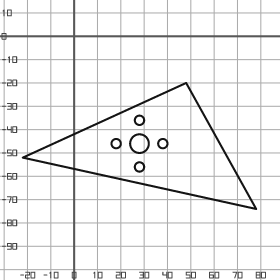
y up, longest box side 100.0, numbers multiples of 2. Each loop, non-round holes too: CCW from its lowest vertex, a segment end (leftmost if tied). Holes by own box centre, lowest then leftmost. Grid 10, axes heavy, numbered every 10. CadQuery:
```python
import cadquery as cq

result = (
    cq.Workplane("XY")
    .moveTo(78.0, -74.0)
    .lineTo(48.0, -20.0)
    .lineTo(-22.0, -52.0)
    .close()
    .moveTo(28.0, -56.0)
    .circle(2.0)
    .moveTo(18.0, -46.0)
    .circle(2.0)
    .moveTo(28.0, -46.0)
    .circle(4.0)
    .moveTo(38.0, -46.0)
    .circle(2.0)
    .moveTo(28.0, -36.0)
    .circle(2.0)
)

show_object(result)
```